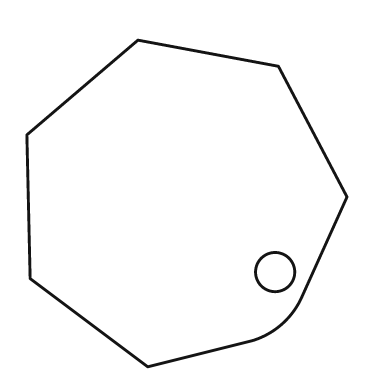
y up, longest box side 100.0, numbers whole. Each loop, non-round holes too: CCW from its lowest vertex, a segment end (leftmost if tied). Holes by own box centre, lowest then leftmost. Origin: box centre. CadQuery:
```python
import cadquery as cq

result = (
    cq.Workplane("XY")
    .moveTo(-12.0, -50.0)
    .lineTo(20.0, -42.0)
    .threePointArc((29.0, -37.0), (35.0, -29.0))
    .lineTo(49.0, 2.0)
    .lineTo(28.0, 42.0)
    .lineTo(-15.0, 50.0)
    .lineTo(-49.0, 21.0)
    .lineTo(-48.0, -23.0)
    .close()
    .moveTo(27.0, -21.0)
    .circle(6.0)
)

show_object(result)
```